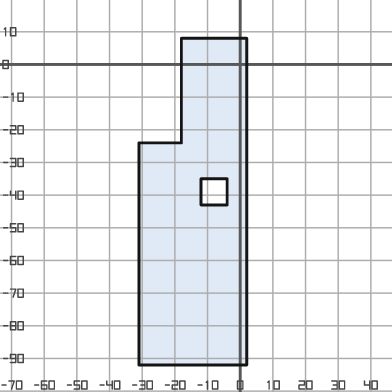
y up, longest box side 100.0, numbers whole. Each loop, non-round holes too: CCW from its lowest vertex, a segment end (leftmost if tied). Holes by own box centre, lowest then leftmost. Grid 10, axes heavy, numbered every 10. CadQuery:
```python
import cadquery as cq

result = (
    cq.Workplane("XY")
    .moveTo(-31.0, -92.0)
    .lineTo(2.0, -92.0)
    .lineTo(2.0, 8.0)
    .lineTo(-18.0, 8.0)
    .lineTo(-18.0, -24.0)
    .lineTo(-31.0, -24.0)
    .close()
    .moveTo(-12.0, -43.0)
    .lineTo(-4.0, -43.0)
    .lineTo(-4.0, -35.0)
    .lineTo(-12.0, -35.0)
    .close()
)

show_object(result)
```